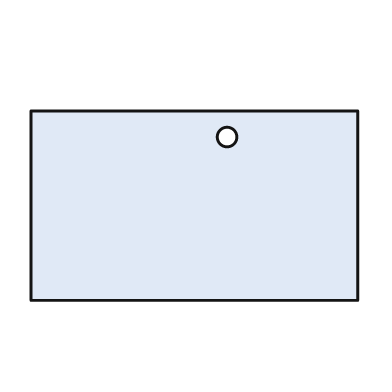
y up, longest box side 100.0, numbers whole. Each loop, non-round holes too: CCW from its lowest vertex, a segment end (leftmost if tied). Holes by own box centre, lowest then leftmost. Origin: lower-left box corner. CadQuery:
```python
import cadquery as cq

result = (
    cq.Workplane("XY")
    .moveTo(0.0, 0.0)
    .lineTo(100.0, 0.0)
    .lineTo(100.0, 58.0)
    .lineTo(0.0, 58.0)
    .close()
    .moveTo(60.0, 50.0)
    .circle(3.0)
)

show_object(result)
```